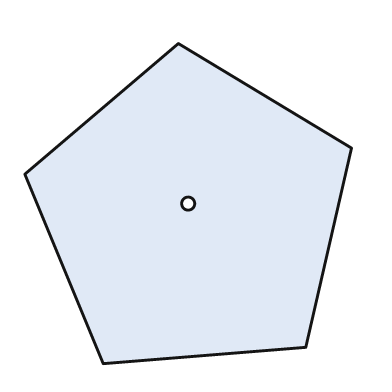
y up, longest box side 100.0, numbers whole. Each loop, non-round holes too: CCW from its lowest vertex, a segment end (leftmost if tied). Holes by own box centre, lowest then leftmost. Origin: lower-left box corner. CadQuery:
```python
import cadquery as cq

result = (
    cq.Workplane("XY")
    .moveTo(24.0, 0.0)
    .lineTo(86.0, 5.0)
    .lineTo(100.0, 66.0)
    .lineTo(47.0, 98.0)
    .lineTo(0.0, 58.0)
    .close()
    .moveTo(50.0, 49.0)
    .circle(2.0)
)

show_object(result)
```